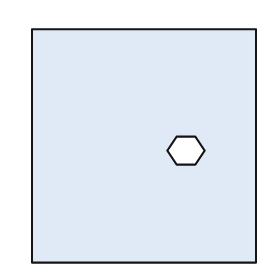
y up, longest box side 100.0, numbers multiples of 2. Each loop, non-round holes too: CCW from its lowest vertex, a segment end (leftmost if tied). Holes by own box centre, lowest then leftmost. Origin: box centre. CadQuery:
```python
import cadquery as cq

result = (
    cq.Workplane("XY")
    .moveTo(-48.0, -50.0)
    .lineTo(48.0, -50.0)
    .lineTo(48.0, 50.0)
    .lineTo(-48.0, 50.0)
    .close()
    .moveTo(14.0, -8.0)
    .lineTo(22.0, -8.0)
    .lineTo(26.0, -2.0)
    .lineTo(22.0, 4.0)
    .lineTo(14.0, 4.0)
    .lineTo(10.0, -2.0)
    .close()
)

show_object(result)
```